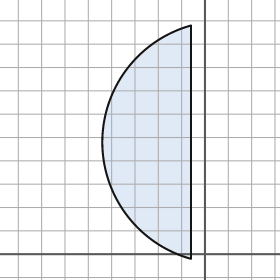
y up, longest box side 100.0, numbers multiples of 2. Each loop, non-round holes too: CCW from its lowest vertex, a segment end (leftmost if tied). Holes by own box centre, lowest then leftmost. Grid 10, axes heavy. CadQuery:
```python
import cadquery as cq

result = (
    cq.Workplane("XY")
    .moveTo(-6.0, -2.0)
    .lineTo(-6.0, 98.0)
    .threePointArc((-44.0, 48.0), (-6.0, -2.0))
    .close()
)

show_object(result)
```